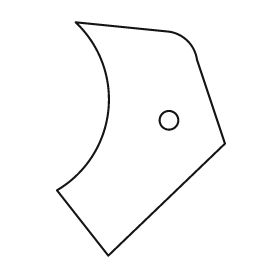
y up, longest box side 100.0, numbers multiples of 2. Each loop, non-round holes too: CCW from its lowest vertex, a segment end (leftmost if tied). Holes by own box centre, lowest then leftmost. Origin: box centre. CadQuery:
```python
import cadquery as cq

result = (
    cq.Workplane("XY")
    .moveTo(-14.0, -50.0)
    .lineTo(36.0, -2.0)
    .lineTo(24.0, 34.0)
    .threePointArc((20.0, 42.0), (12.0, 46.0))
    .lineTo(-28.0, 50.0)
    .threePointArc((-14.0, 12.0), (-36.0, -22.0))
    .close()
    .moveTo(12.0, 8.0)
    .circle(4.0)
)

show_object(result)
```